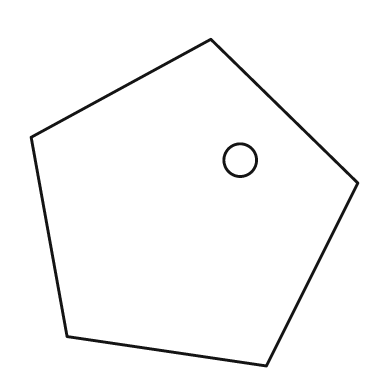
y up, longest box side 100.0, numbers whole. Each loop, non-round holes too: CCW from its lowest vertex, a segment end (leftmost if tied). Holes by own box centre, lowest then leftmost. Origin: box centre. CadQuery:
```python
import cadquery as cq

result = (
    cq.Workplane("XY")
    .moveTo(22.0, -50.0)
    .lineTo(50.0, 6.0)
    .lineTo(5.0, 50.0)
    .lineTo(-50.0, 20.0)
    .lineTo(-39.0, -41.0)
    .close()
    .moveTo(14.0, 13.0)
    .circle(5.0)
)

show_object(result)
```